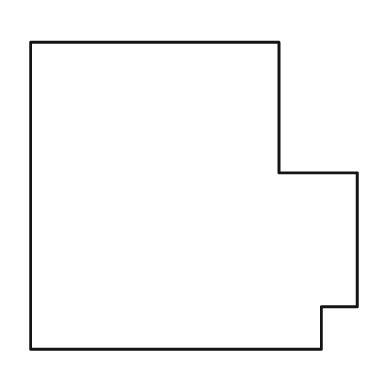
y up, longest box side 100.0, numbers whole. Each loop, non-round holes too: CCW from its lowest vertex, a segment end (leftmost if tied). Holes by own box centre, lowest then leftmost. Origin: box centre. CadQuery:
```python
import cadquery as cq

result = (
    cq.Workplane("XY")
    .moveTo(-50.0, -47.0)
    .lineTo(39.0, -47.0)
    .lineTo(39.0, -34.0)
    .lineTo(50.0, -34.0)
    .lineTo(50.0, 7.0)
    .lineTo(26.0, 7.0)
    .lineTo(26.0, 47.0)
    .lineTo(-50.0, 47.0)
    .close()
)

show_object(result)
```